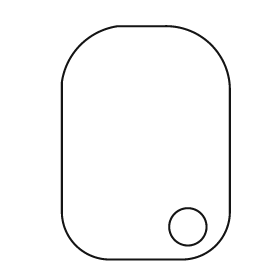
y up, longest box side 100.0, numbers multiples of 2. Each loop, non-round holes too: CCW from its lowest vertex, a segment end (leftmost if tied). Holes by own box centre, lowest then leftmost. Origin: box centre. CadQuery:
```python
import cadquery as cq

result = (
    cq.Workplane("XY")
    .moveTo(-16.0, -50.0)
    .lineTo(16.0, -50.0)
    .threePointArc((30.0, -44.0), (36.0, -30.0))
    .lineTo(36.0, 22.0)
    .threePointArc((28.0, 42.0), (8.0, 50.0))
    .lineTo(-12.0, 50.0)
    .threePointArc((-28.0, 42.0), (-36.0, 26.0))
    .lineTo(-36.0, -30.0)
    .threePointArc((-30.0, -44.0), (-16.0, -50.0))
    .close()
    .moveTo(18.0, -36.0)
    .circle(8.0)
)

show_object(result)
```